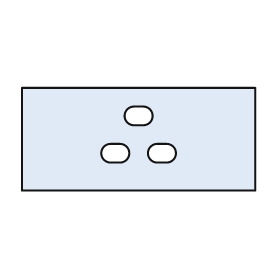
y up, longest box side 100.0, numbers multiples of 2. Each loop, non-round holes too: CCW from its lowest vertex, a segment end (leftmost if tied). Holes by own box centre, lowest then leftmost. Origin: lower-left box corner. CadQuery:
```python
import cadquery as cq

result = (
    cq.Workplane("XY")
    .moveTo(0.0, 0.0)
    .lineTo(100.0, 0.0)
    .lineTo(100.0, 44.0)
    .lineTo(0.0, 44.0)
    .close()
    .moveTo(38.0, 12.0)
    .lineTo(42.0, 12.0)
    .threePointArc((46.0, 16.0), (42.0, 20.0))
    .lineTo(38.0, 20.0)
    .threePointArc((34.0, 16.0), (38.0, 12.0))
    .close()
    .moveTo(58.0, 12.0)
    .lineTo(62.0, 12.0)
    .threePointArc((66.0, 16.0), (62.0, 20.0))
    .lineTo(58.0, 20.0)
    .threePointArc((54.0, 16.0), (58.0, 12.0))
    .close()
    .moveTo(48.0, 28.0)
    .lineTo(52.0, 28.0)
    .threePointArc((56.0, 32.0), (52.0, 36.0))
    .lineTo(48.0, 36.0)
    .threePointArc((44.0, 32.0), (48.0, 28.0))
    .close()
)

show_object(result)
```